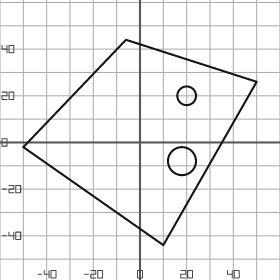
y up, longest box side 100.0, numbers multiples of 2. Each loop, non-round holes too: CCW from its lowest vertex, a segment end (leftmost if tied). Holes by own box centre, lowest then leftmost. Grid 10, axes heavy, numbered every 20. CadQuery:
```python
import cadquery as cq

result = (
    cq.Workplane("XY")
    .moveTo(10.0, -44.0)
    .lineTo(50.0, 26.0)
    .lineTo(-6.0, 44.0)
    .lineTo(-50.0, -2.0)
    .close()
    .moveTo(18.0, -8.0)
    .circle(6.0)
    .moveTo(20.0, 20.0)
    .circle(4.0)
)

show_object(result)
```